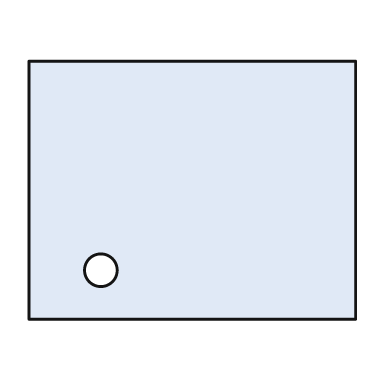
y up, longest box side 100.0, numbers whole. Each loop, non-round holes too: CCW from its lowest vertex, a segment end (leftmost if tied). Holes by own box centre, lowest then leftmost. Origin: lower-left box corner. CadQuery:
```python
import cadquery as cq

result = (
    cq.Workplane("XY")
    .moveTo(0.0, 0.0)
    .lineTo(100.0, 0.0)
    .lineTo(100.0, 79.0)
    .lineTo(0.0, 79.0)
    .close()
    .moveTo(22.0, 15.0)
    .circle(5.0)
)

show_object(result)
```